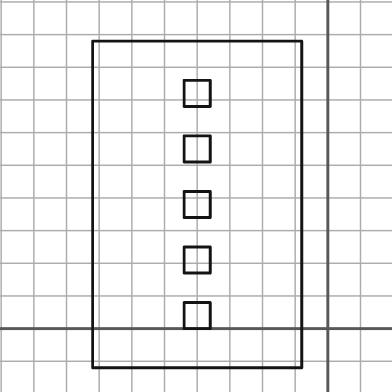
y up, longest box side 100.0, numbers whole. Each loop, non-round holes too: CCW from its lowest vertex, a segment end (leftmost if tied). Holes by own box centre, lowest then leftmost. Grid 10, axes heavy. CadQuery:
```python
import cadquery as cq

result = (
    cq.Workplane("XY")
    .moveTo(-72.0, -12.0)
    .lineTo(-8.0, -12.0)
    .lineTo(-8.0, 88.0)
    .lineTo(-72.0, 88.0)
    .close()
    .moveTo(-44.0, 0.0)
    .lineTo(-36.0, 0.0)
    .lineTo(-36.0, 8.0)
    .lineTo(-44.0, 8.0)
    .close()
    .moveTo(-44.0, 17.0)
    .lineTo(-36.0, 17.0)
    .lineTo(-36.0, 25.0)
    .lineTo(-44.0, 25.0)
    .close()
    .moveTo(-44.0, 34.0)
    .lineTo(-36.0, 34.0)
    .lineTo(-36.0, 42.0)
    .lineTo(-44.0, 42.0)
    .close()
    .moveTo(-44.0, 51.0)
    .lineTo(-36.0, 51.0)
    .lineTo(-36.0, 59.0)
    .lineTo(-44.0, 59.0)
    .close()
    .moveTo(-44.0, 68.0)
    .lineTo(-36.0, 68.0)
    .lineTo(-36.0, 76.0)
    .lineTo(-44.0, 76.0)
    .close()
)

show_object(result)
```